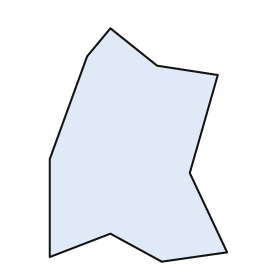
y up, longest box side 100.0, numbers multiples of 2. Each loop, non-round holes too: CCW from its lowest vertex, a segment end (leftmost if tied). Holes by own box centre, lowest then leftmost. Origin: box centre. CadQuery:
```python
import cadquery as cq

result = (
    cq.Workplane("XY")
    .moveTo(10.0, -50.0)
    .lineTo(38.0, -46.0)
    .lineTo(22.0, -12.0)
    .lineTo(34.0, 30.0)
    .lineTo(8.0, 34.0)
    .lineTo(-12.0, 50.0)
    .lineTo(-22.0, 38.0)
    .lineTo(-38.0, -6.0)
    .lineTo(-38.0, -48.0)
    .lineTo(-12.0, -38.0)
    .close()
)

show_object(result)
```